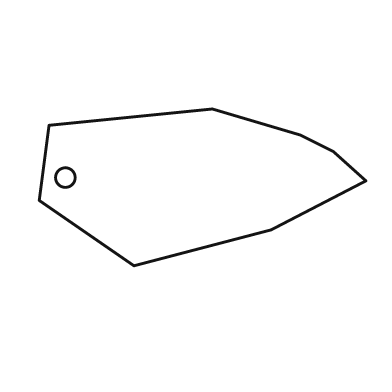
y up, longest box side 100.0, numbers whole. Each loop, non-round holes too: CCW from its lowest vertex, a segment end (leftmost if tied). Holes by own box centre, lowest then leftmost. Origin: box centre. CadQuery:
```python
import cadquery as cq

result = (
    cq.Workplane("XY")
    .moveTo(-21.0, -24.0)
    .lineTo(21.0, -13.0)
    .lineTo(50.0, 2.0)
    .lineTo(40.0, 11.0)
    .lineTo(30.0, 16.0)
    .lineTo(3.0, 24.0)
    .lineTo(-47.0, 19.0)
    .lineTo(-50.0, -4.0)
    .close()
    .moveTo(-42.0, 3.0)
    .circle(3.0)
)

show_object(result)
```